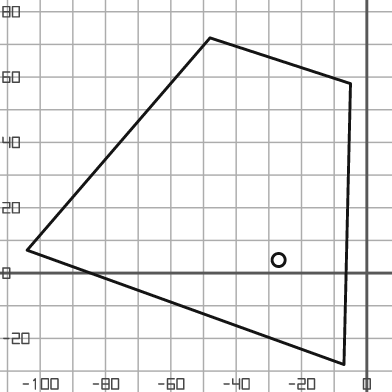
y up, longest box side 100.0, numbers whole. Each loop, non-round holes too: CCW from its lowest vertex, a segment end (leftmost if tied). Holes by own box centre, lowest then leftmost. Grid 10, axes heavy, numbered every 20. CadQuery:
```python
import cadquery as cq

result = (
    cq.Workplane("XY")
    .moveTo(-7.0, -28.0)
    .lineTo(-5.0, 58.0)
    .lineTo(-48.0, 72.0)
    .lineTo(-104.0, 7.0)
    .close()
    .moveTo(-27.0, 4.0)
    .circle(2.0)
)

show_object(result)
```